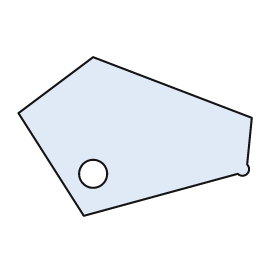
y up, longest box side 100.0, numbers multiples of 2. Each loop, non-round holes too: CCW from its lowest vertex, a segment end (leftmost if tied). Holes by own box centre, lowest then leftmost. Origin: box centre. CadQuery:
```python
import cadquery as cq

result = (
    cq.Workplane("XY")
    .moveTo(-22.0, -34.0)
    .lineTo(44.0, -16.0)
    .threePointArc((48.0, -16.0), (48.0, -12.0))
    .lineTo(50.0, 8.0)
    .lineTo(-18.0, 34.0)
    .lineTo(-50.0, 10.0)
    .close()
    .moveTo(-18.0, -16.0)
    .circle(6.0)
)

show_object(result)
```